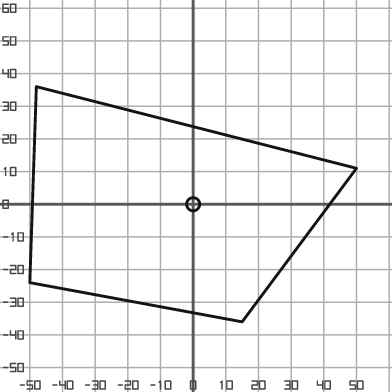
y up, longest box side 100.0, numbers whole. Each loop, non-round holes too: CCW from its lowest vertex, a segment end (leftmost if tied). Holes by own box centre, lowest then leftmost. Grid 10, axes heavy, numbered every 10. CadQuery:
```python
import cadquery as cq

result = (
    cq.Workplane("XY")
    .moveTo(15.0, -36.0)
    .lineTo(50.0, 11.0)
    .lineTo(-48.0, 36.0)
    .lineTo(-50.0, -24.0)
    .close()
    .moveTo(0.0, 0.0)
    .circle(2.0)
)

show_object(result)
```